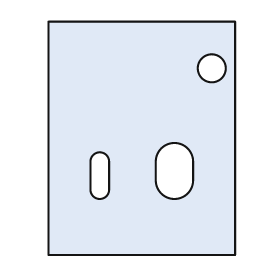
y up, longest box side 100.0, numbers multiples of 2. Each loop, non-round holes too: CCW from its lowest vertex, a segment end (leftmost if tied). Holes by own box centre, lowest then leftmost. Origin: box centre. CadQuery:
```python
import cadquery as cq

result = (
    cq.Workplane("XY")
    .moveTo(-40.0, -50.0)
    .lineTo(40.0, -50.0)
    .lineTo(40.0, 50.0)
    .lineTo(-40.0, 50.0)
    .close()
    .moveTo(-22.0, -22.0)
    .threePointArc((-18.0, -26.0), (-14.0, -22.0))
    .lineTo(-14.0, -10.0)
    .threePointArc((-18.0, -6.0), (-22.0, -10.0))
    .close()
    .moveTo(6.0, -18.0)
    .threePointArc((14.0, -26.0), (22.0, -18.0))
    .lineTo(22.0, -10.0)
    .threePointArc((14.0, -2.0), (6.0, -10.0))
    .close()
    .moveTo(30.0, 30.0)
    .circle(6.0)
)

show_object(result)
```